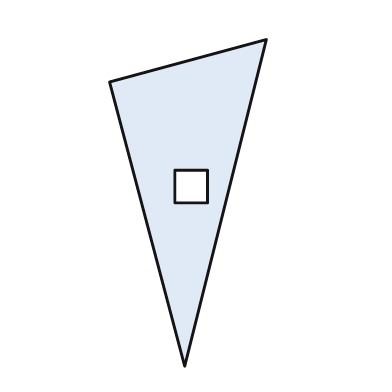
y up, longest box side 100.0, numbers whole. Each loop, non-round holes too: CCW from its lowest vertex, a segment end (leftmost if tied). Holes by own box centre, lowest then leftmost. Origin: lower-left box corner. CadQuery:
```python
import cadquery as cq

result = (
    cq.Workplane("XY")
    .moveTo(23.0, 0.0)
    .lineTo(48.0, 100.0)
    .lineTo(0.0, 87.0)
    .close()
    .moveTo(20.0, 50.0)
    .lineTo(30.0, 50.0)
    .lineTo(30.0, 60.0)
    .lineTo(20.0, 60.0)
    .close()
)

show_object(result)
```